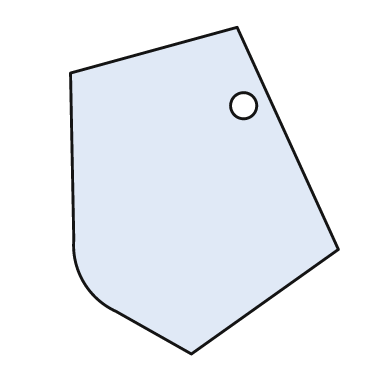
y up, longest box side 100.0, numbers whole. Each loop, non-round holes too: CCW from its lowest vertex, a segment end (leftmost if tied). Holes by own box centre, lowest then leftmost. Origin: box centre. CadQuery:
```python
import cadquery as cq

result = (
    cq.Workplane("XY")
    .moveTo(-4.0, -50.0)
    .lineTo(41.0, -18.0)
    .lineTo(10.0, 50.0)
    .lineTo(-41.0, 36.0)
    .lineTo(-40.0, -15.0)
    .threePointArc((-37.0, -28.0), (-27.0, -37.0))
    .close()
    .moveTo(12.0, 26.0)
    .circle(4.0)
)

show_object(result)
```